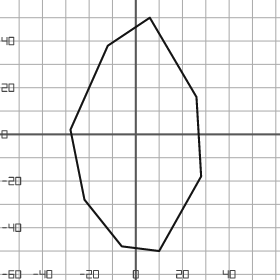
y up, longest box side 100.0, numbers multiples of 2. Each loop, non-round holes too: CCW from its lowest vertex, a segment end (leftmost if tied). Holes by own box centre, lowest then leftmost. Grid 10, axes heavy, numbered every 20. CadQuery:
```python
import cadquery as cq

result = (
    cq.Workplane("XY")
    .moveTo(10.0, -50.0)
    .lineTo(28.0, -18.0)
    .lineTo(26.0, 16.0)
    .lineTo(6.0, 50.0)
    .lineTo(-12.0, 38.0)
    .lineTo(-28.0, 2.0)
    .lineTo(-22.0, -28.0)
    .lineTo(-6.0, -48.0)
    .close()
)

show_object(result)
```